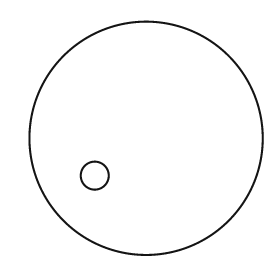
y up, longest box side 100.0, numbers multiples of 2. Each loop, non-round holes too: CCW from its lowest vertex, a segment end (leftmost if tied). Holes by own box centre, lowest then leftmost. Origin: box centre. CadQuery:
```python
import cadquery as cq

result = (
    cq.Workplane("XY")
    .moveTo(0.0, 0.0)
    .circle(50.0)
    .moveTo(-22.0, -16.0)
    .circle(6.0)
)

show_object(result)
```